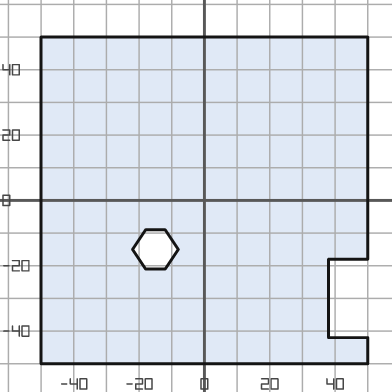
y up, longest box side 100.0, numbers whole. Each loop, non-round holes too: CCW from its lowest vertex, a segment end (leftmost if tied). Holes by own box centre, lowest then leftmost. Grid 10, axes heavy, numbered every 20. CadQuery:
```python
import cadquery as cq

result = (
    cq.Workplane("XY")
    .moveTo(-50.0, -50.0)
    .lineTo(50.0, -50.0)
    .lineTo(50.0, -42.0)
    .lineTo(38.0, -42.0)
    .lineTo(38.0, -18.0)
    .lineTo(50.0, -18.0)
    .lineTo(50.0, 50.0)
    .lineTo(-50.0, 50.0)
    .close()
    .moveTo(-18.0, -21.0)
    .lineTo(-12.0, -21.0)
    .lineTo(-8.0, -15.0)
    .lineTo(-12.0, -9.0)
    .lineTo(-18.0, -9.0)
    .lineTo(-22.0, -15.0)
    .close()
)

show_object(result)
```